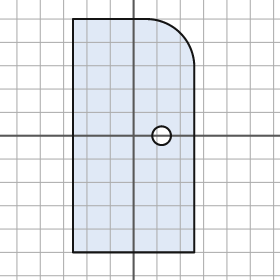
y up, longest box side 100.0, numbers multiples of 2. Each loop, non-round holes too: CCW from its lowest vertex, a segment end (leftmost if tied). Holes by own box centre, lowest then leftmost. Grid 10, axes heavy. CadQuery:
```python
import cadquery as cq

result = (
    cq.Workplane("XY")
    .moveTo(-26.0, -50.0)
    .lineTo(26.0, -50.0)
    .lineTo(26.0, 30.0)
    .threePointArc((20.0, 44.0), (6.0, 50.0))
    .lineTo(-26.0, 50.0)
    .close()
    .moveTo(12.0, 0.0)
    .circle(4.0)
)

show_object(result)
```